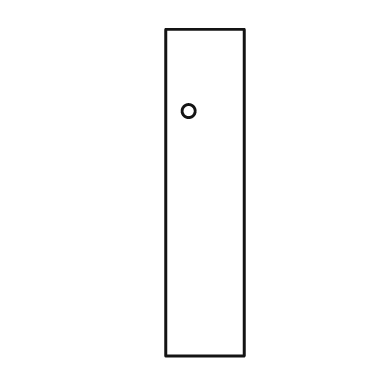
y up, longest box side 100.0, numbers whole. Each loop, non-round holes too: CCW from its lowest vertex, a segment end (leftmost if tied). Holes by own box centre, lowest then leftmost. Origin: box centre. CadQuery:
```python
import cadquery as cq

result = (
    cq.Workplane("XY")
    .moveTo(-12.0, -50.0)
    .lineTo(12.0, -50.0)
    .lineTo(12.0, 50.0)
    .lineTo(-12.0, 50.0)
    .close()
    .moveTo(-5.0, 25.0)
    .circle(2.0)
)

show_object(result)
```